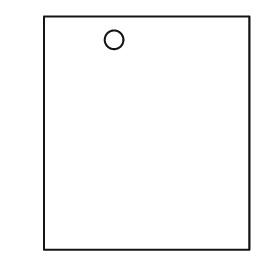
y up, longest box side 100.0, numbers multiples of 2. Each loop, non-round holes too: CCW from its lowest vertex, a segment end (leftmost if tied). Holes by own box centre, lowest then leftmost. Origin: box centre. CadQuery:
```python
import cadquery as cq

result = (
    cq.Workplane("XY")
    .moveTo(-44.0, -50.0)
    .lineTo(44.0, -50.0)
    .lineTo(44.0, 50.0)
    .lineTo(-44.0, 50.0)
    .close()
    .moveTo(-14.0, 40.0)
    .circle(4.0)
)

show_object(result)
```